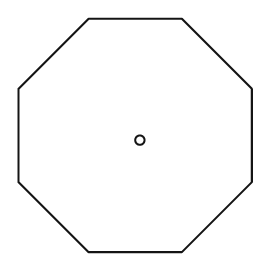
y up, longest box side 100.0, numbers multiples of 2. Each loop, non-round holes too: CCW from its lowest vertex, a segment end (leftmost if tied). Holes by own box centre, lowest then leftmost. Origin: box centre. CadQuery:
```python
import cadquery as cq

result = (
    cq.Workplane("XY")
    .moveTo(-20.0, -50.0)
    .lineTo(20.0, -50.0)
    .lineTo(50.0, -20.0)
    .lineTo(50.0, 20.0)
    .lineTo(20.0, 50.0)
    .lineTo(-20.0, 50.0)
    .lineTo(-50.0, 20.0)
    .lineTo(-50.0, -20.0)
    .close()
    .moveTo(2.0, -2.0)
    .circle(2.0)
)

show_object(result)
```